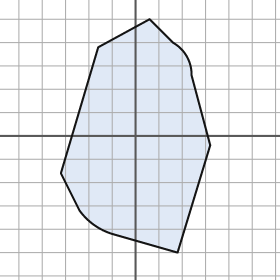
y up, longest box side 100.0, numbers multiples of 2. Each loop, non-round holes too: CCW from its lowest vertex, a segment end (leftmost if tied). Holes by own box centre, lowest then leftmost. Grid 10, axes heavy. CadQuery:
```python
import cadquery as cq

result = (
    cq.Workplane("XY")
    .moveTo(18.0, -50.0)
    .lineTo(32.0, -4.0)
    .lineTo(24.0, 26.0)
    .threePointArc((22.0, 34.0), (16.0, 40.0))
    .lineTo(6.0, 50.0)
    .lineTo(-16.0, 38.0)
    .lineTo(-32.0, -16.0)
    .lineTo(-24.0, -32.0)
    .threePointArc((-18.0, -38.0), (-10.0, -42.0))
    .close()
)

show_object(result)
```